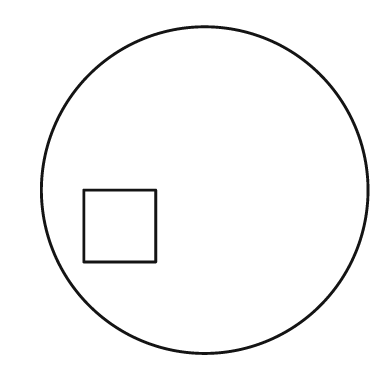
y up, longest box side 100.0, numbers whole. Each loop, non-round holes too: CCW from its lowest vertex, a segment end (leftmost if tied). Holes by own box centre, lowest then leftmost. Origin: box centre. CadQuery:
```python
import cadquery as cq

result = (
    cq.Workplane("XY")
    .moveTo(0.0, 0.0)
    .circle(50.0)
    .moveTo(-37.0, -22.0)
    .lineTo(-15.0, -22.0)
    .lineTo(-15.0, 0.0)
    .lineTo(-37.0, 0.0)
    .close()
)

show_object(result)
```